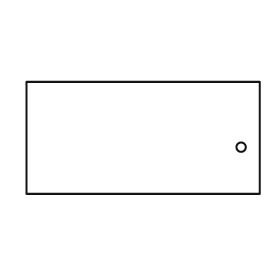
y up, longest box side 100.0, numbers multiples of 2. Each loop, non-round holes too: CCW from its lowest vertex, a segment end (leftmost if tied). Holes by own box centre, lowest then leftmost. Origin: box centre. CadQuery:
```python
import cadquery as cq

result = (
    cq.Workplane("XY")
    .moveTo(-50.0, -24.0)
    .lineTo(50.0, -24.0)
    .lineTo(50.0, 24.0)
    .lineTo(-50.0, 24.0)
    .close()
    .moveTo(42.0, -4.0)
    .circle(2.0)
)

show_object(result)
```